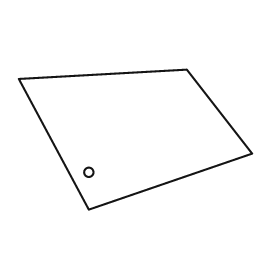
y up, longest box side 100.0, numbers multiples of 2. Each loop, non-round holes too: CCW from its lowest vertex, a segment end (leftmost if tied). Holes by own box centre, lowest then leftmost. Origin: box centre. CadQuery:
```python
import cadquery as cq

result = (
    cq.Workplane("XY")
    .moveTo(-20.0, -30.0)
    .lineTo(50.0, -6.0)
    .lineTo(22.0, 30.0)
    .lineTo(-50.0, 26.0)
    .close()
    .moveTo(-20.0, -14.0)
    .circle(2.0)
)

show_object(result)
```